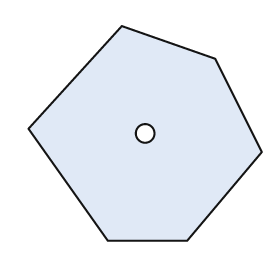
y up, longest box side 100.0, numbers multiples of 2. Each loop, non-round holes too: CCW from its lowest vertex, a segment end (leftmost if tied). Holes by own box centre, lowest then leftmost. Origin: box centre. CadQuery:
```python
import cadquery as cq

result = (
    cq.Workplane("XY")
    .moveTo(-16.0, -46.0)
    .lineTo(18.0, -46.0)
    .lineTo(50.0, -8.0)
    .lineTo(30.0, 32.0)
    .lineTo(-10.0, 46.0)
    .lineTo(-50.0, 2.0)
    .close()
    .moveTo(0.0, 0.0)
    .circle(4.0)
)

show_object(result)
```